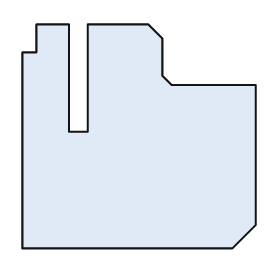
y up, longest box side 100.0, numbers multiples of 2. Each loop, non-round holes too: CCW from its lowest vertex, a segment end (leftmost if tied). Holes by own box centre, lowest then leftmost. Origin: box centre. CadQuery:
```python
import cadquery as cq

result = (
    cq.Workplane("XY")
    .moveTo(-50.0, -48.0)
    .lineTo(40.0, -48.0)
    .lineTo(50.0, -38.0)
    .lineTo(50.0, 22.0)
    .lineTo(14.0, 22.0)
    .lineTo(10.0, 26.0)
    .lineTo(10.0, 42.0)
    .lineTo(4.0, 48.0)
    .lineTo(-22.0, 48.0)
    .lineTo(-22.0, 2.0)
    .lineTo(-30.0, 2.0)
    .lineTo(-30.0, 48.0)
    .lineTo(-44.0, 48.0)
    .lineTo(-44.0, 36.0)
    .lineTo(-50.0, 36.0)
    .close()
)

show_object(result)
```